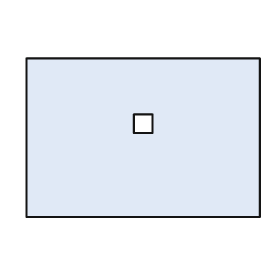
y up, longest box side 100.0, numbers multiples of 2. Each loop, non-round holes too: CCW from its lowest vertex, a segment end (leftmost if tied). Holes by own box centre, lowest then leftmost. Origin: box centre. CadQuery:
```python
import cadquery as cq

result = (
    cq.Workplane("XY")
    .moveTo(-50.0, -34.0)
    .lineTo(50.0, -34.0)
    .lineTo(50.0, 34.0)
    .lineTo(-50.0, 34.0)
    .close()
    .moveTo(-4.0, 2.0)
    .lineTo(4.0, 2.0)
    .lineTo(4.0, 10.0)
    .lineTo(-4.0, 10.0)
    .close()
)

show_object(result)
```